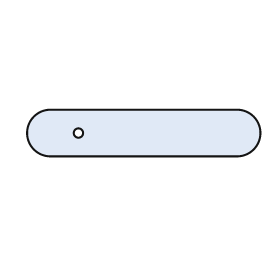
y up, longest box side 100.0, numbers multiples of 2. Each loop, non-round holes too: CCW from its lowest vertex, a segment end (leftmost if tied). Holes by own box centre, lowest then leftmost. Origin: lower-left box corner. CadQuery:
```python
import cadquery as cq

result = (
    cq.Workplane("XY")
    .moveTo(10.0, 0.0)
    .lineTo(90.0, 0.0)
    .threePointArc((100.0, 10.0), (90.0, 20.0))
    .lineTo(10.0, 20.0)
    .threePointArc((0.0, 10.0), (10.0, 0.0))
    .close()
    .moveTo(22.0, 10.0)
    .circle(2.0)
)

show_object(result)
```